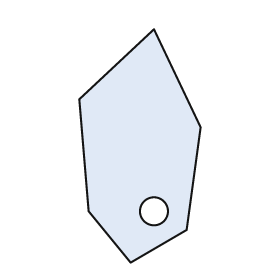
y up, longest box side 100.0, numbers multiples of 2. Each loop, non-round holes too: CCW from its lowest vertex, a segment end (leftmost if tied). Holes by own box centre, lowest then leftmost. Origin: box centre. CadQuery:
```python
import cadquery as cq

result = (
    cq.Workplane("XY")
    .moveTo(-4.0, -50.0)
    .lineTo(20.0, -36.0)
    .lineTo(26.0, 8.0)
    .lineTo(6.0, 50.0)
    .lineTo(-26.0, 20.0)
    .lineTo(-22.0, -28.0)
    .close()
    .moveTo(6.0, -28.0)
    .circle(6.0)
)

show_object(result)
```